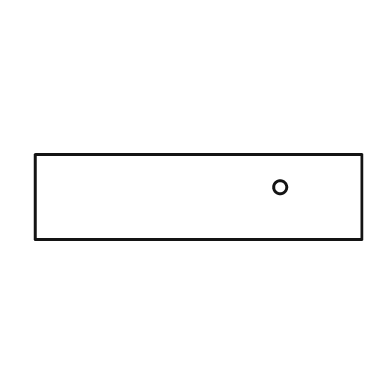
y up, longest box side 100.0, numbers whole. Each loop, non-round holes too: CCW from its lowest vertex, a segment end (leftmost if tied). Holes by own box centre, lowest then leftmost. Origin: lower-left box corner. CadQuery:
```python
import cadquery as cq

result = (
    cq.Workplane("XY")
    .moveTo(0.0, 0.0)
    .lineTo(100.0, 0.0)
    .lineTo(100.0, 26.0)
    .lineTo(0.0, 26.0)
    .close()
    .moveTo(75.0, 16.0)
    .circle(2.0)
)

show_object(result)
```